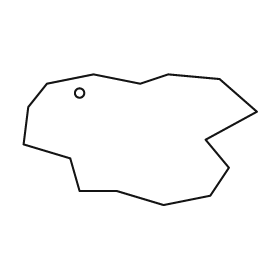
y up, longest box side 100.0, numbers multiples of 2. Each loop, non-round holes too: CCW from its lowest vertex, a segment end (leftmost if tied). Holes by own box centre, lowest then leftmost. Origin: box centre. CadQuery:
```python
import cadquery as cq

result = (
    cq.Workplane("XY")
    .moveTo(10.0, -28.0)
    .lineTo(30.0, -24.0)
    .lineTo(38.0, -12.0)
    .lineTo(28.0, 0.0)
    .lineTo(50.0, 12.0)
    .lineTo(34.0, 26.0)
    .lineTo(12.0, 28.0)
    .lineTo(0.0, 24.0)
    .lineTo(-20.0, 28.0)
    .lineTo(-40.0, 24.0)
    .lineTo(-48.0, 14.0)
    .lineTo(-50.0, -2.0)
    .lineTo(-30.0, -8.0)
    .lineTo(-26.0, -22.0)
    .lineTo(-10.0, -22.0)
    .close()
    .moveTo(-26.0, 20.0)
    .circle(2.0)
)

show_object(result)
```